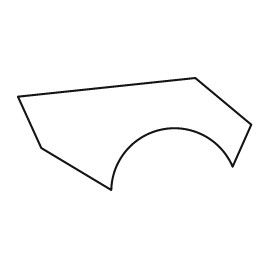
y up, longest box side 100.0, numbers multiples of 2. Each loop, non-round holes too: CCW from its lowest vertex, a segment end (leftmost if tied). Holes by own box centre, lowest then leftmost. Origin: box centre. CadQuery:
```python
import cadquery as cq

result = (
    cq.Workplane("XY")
    .moveTo(-10.0, -24.0)
    .threePointArc((12.0, 2.0), (42.0, -14.0))
    .lineTo(50.0, 4.0)
    .lineTo(26.0, 24.0)
    .lineTo(-50.0, 16.0)
    .lineTo(-40.0, -6.0)
    .close()
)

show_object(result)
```